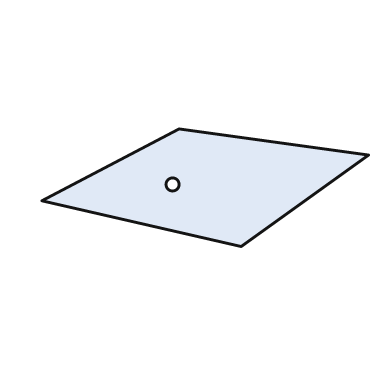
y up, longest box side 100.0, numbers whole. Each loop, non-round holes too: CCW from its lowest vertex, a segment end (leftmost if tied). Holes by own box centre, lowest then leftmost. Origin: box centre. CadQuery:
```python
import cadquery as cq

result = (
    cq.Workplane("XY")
    .moveTo(11.0, -18.0)
    .lineTo(50.0, 10.0)
    .lineTo(-8.0, 18.0)
    .lineTo(-50.0, -4.0)
    .close()
    .moveTo(-10.0, 1.0)
    .circle(2.0)
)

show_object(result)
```